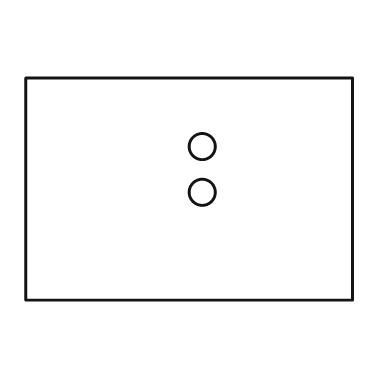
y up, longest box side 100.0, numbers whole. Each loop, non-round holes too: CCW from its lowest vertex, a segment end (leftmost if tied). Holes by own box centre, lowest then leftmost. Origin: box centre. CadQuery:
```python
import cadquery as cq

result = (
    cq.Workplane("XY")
    .moveTo(-50.0, -34.0)
    .lineTo(50.0, -34.0)
    .lineTo(50.0, 34.0)
    .lineTo(-50.0, 34.0)
    .close()
    .moveTo(4.0, -1.0)
    .circle(4.0)
    .moveTo(4.0, 13.0)
    .circle(4.0)
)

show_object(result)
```